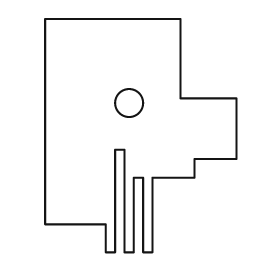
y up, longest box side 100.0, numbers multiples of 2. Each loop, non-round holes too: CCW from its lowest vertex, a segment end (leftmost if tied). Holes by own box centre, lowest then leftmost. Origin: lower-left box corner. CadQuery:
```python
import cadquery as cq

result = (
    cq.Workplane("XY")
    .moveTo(26.0, 0.0)
    .lineTo(30.0, 0.0)
    .lineTo(30.0, 44.0)
    .lineTo(34.0, 44.0)
    .lineTo(34.0, 0.0)
    .lineTo(38.0, 0.0)
    .lineTo(38.0, 32.0)
    .lineTo(42.0, 32.0)
    .lineTo(42.0, 0.0)
    .lineTo(46.0, 0.0)
    .lineTo(46.0, 32.0)
    .lineTo(64.0, 32.0)
    .lineTo(64.0, 40.0)
    .lineTo(82.0, 40.0)
    .lineTo(82.0, 66.0)
    .lineTo(58.0, 66.0)
    .lineTo(58.0, 100.0)
    .lineTo(0.0, 100.0)
    .lineTo(0.0, 12.0)
    .lineTo(26.0, 12.0)
    .close()
    .moveTo(36.0, 64.0)
    .circle(6.0)
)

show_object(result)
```